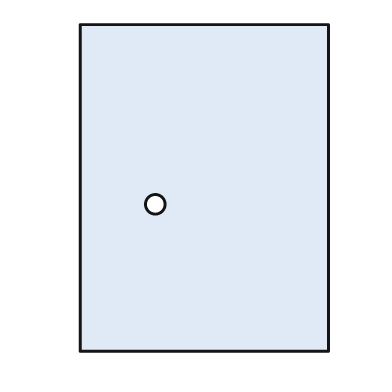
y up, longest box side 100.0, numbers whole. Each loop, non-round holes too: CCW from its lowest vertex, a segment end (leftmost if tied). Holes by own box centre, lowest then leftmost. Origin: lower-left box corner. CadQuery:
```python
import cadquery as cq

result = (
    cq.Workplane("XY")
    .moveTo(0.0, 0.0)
    .lineTo(76.0, 0.0)
    .lineTo(76.0, 100.0)
    .lineTo(0.0, 100.0)
    .close()
    .moveTo(23.0, 45.0)
    .circle(3.0)
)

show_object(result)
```